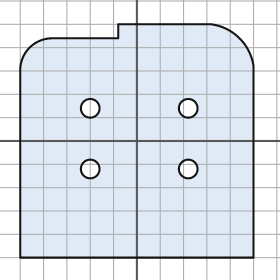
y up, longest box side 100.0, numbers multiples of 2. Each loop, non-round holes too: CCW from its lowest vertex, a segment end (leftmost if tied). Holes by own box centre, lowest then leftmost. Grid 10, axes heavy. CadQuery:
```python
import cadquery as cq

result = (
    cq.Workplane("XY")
    .moveTo(-50.0, -50.0)
    .lineTo(50.0, -50.0)
    .lineTo(50.0, 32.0)
    .threePointArc((44.0, 44.0), (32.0, 50.0))
    .lineTo(-8.0, 50.0)
    .lineTo(-8.0, 44.0)
    .lineTo(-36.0, 44.0)
    .threePointArc((-46.0, 40.0), (-50.0, 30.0))
    .close()
    .moveTo(-20.0, -12.0)
    .circle(4.0)
    .moveTo(22.0, -12.0)
    .circle(4.0)
    .moveTo(-20.0, 14.0)
    .circle(4.0)
    .moveTo(22.0, 14.0)
    .circle(4.0)
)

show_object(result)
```